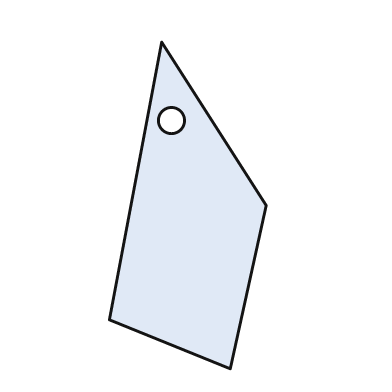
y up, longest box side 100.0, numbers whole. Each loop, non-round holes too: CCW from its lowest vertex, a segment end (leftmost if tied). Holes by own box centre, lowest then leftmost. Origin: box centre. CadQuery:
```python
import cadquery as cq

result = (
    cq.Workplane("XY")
    .moveTo(13.0, -50.0)
    .lineTo(24.0, 0.0)
    .lineTo(-8.0, 50.0)
    .lineTo(-24.0, -35.0)
    .close()
    .moveTo(-5.0, 26.0)
    .circle(4.0)
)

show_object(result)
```